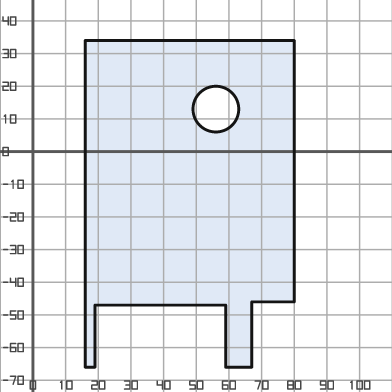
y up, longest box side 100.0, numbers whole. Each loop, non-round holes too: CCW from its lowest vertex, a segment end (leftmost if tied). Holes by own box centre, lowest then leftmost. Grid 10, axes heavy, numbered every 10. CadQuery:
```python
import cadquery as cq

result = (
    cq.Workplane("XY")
    .moveTo(16.0, -66.0)
    .lineTo(19.0, -66.0)
    .lineTo(19.0, -47.0)
    .lineTo(59.0, -47.0)
    .lineTo(59.0, -66.0)
    .lineTo(67.0, -66.0)
    .lineTo(67.0, -46.0)
    .lineTo(80.0, -46.0)
    .lineTo(80.0, 34.0)
    .lineTo(16.0, 34.0)
    .close()
    .moveTo(56.0, 13.0)
    .circle(7.0)
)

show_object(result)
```